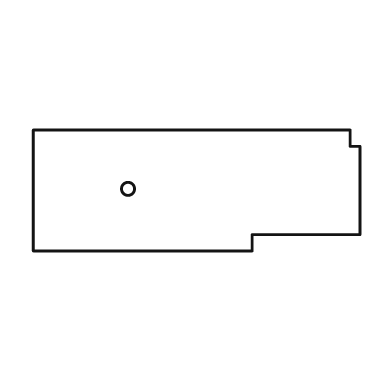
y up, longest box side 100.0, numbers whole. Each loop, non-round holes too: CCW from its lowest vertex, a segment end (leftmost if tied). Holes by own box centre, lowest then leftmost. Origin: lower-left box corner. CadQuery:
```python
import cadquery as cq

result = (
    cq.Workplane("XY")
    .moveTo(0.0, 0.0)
    .lineTo(67.0, 0.0)
    .lineTo(67.0, 5.0)
    .lineTo(100.0, 5.0)
    .lineTo(100.0, 32.0)
    .lineTo(97.0, 32.0)
    .lineTo(97.0, 37.0)
    .lineTo(0.0, 37.0)
    .close()
    .moveTo(29.0, 19.0)
    .circle(2.0)
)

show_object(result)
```